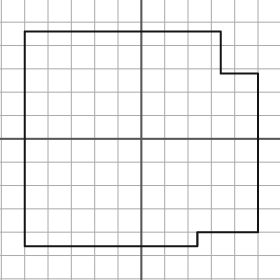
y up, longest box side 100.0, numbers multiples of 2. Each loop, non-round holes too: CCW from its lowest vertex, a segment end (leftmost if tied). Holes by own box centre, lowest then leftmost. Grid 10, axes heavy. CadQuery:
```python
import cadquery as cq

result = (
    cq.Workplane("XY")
    .moveTo(-50.0, -46.0)
    .lineTo(24.0, -46.0)
    .lineTo(24.0, -40.0)
    .lineTo(50.0, -40.0)
    .lineTo(50.0, 28.0)
    .lineTo(34.0, 28.0)
    .lineTo(34.0, 46.0)
    .lineTo(-50.0, 46.0)
    .close()
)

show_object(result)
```